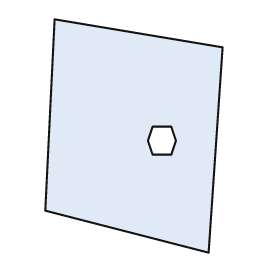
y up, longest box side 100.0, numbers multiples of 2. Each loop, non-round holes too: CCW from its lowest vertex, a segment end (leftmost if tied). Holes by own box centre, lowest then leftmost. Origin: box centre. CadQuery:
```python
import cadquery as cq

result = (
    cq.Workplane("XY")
    .moveTo(32.0, -50.0)
    .lineTo(38.0, 38.0)
    .lineTo(-34.0, 50.0)
    .lineTo(-38.0, -32.0)
    .close()
    .moveTo(8.0, -8.0)
    .lineTo(16.0, -8.0)
    .lineTo(18.0, -2.0)
    .lineTo(16.0, 4.0)
    .lineTo(8.0, 4.0)
    .lineTo(6.0, -2.0)
    .close()
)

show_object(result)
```